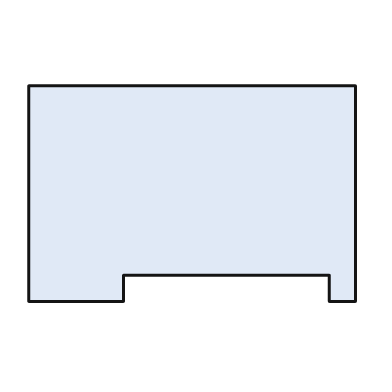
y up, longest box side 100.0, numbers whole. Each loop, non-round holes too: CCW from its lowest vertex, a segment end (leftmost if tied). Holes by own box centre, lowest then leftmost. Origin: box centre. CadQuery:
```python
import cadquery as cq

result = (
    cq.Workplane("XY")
    .moveTo(-50.0, -33.0)
    .lineTo(-21.0, -33.0)
    .lineTo(-21.0, -25.0)
    .lineTo(42.0, -25.0)
    .lineTo(42.0, -33.0)
    .lineTo(50.0, -33.0)
    .lineTo(50.0, 33.0)
    .lineTo(-50.0, 33.0)
    .close()
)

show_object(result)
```